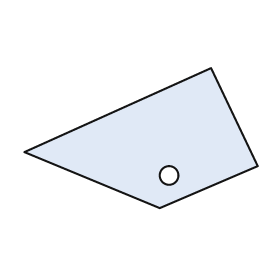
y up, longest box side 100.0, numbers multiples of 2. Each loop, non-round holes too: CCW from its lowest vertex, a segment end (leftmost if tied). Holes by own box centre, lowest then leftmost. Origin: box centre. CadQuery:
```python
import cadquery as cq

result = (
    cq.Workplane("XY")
    .moveTo(8.0, -30.0)
    .lineTo(50.0, -12.0)
    .lineTo(30.0, 30.0)
    .lineTo(-50.0, -6.0)
    .close()
    .moveTo(12.0, -16.0)
    .circle(4.0)
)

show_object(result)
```